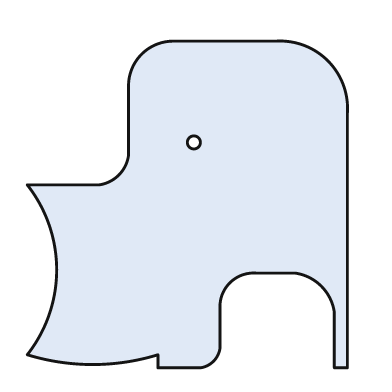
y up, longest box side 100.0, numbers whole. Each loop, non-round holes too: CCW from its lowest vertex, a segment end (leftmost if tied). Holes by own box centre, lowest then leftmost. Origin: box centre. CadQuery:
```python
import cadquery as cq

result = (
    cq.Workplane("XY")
    .moveTo(-9.0, -50.0)
    .lineTo(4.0, -50.0)
    .threePointArc((8.0, -48.0), (10.0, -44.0))
    .lineTo(10.0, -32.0)
    .threePointArc((13.0, -24.0), (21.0, -21.0))
    .lineTo(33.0, -21.0)
    .threePointArc((41.0, -25.0), (45.0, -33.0))
    .lineTo(45.0, -50.0)
    .lineTo(49.0, -50.0)
    .lineTo(49.0, 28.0)
    .threePointArc((43.0, 44.0), (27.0, 50.0))
    .lineTo(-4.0, 50.0)
    .threePointArc((-14.0, 46.0), (-18.0, 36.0))
    .lineTo(-18.0, 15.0)
    .threePointArc((-21.0, 9.0), (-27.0, 6.0))
    .lineTo(-49.0, 6.0)
    .threePointArc((-40.0, -20.0), (-49.0, -46.0))
    .threePointArc((-29.0, -49.0), (-9.0, -46.0))
    .close()
    .moveTo(2.0, 19.0)
    .circle(2.0)
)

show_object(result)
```